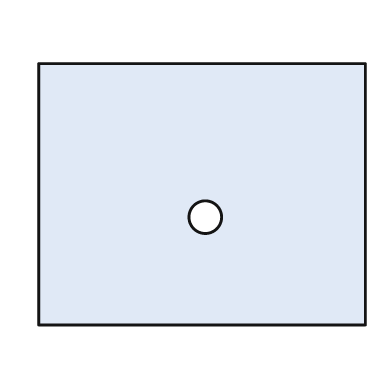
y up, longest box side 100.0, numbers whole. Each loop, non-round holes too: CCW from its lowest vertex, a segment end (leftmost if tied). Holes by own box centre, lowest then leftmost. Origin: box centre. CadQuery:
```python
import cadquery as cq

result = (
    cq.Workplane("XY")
    .moveTo(-50.0, -40.0)
    .lineTo(50.0, -40.0)
    .lineTo(50.0, 40.0)
    .lineTo(-50.0, 40.0)
    .close()
    .moveTo(1.0, -7.0)
    .circle(5.0)
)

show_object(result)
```